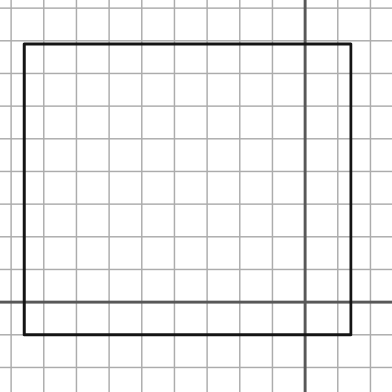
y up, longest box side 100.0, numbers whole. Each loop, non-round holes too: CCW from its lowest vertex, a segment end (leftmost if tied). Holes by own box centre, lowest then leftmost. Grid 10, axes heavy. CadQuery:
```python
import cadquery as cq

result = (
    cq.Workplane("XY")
    .moveTo(-86.0, -10.0)
    .lineTo(14.0, -10.0)
    .lineTo(14.0, 79.0)
    .lineTo(-86.0, 79.0)
    .close()
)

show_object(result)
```